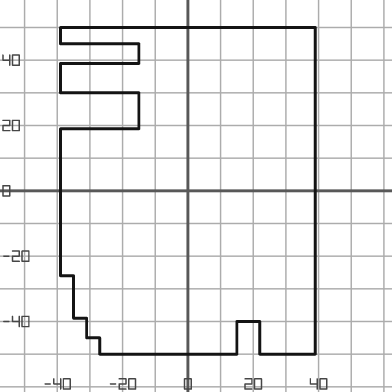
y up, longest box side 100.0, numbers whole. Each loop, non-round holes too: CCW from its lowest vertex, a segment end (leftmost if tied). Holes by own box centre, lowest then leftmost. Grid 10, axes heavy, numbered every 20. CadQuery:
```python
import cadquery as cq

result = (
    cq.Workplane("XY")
    .moveTo(-27.0, -50.0)
    .lineTo(15.0, -50.0)
    .lineTo(15.0, -40.0)
    .lineTo(22.0, -40.0)
    .lineTo(22.0, -50.0)
    .lineTo(39.0, -50.0)
    .lineTo(39.0, 50.0)
    .lineTo(-39.0, 50.0)
    .lineTo(-39.0, 45.0)
    .lineTo(-15.0, 45.0)
    .lineTo(-15.0, 39.0)
    .lineTo(-39.0, 39.0)
    .lineTo(-39.0, 30.0)
    .lineTo(-15.0, 30.0)
    .lineTo(-15.0, 19.0)
    .lineTo(-39.0, 19.0)
    .lineTo(-39.0, -26.0)
    .lineTo(-35.0, -26.0)
    .lineTo(-35.0, -39.0)
    .lineTo(-31.0, -39.0)
    .lineTo(-31.0, -45.0)
    .lineTo(-27.0, -45.0)
    .close()
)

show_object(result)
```